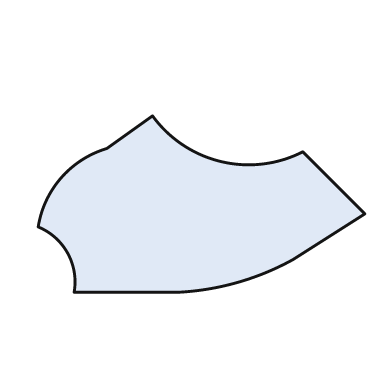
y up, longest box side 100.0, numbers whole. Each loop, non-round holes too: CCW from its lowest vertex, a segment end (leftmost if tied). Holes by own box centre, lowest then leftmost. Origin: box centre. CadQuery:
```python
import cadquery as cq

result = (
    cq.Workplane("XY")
    .moveTo(-39.0, -27.0)
    .lineTo(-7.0, -27.0)
    .threePointArc((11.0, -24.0), (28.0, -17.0))
    .lineTo(50.0, -3.0)
    .lineTo(31.0, 16.0)
    .threePointArc((6.0, 13.0), (-15.0, 27.0))
    .lineTo(-29.0, 17.0)
    .threePointArc((-43.0, 8.0), (-50.0, -7.0))
    .threePointArc((-41.0, -15.0), (-39.0, -27.0))
    .close()
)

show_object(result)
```